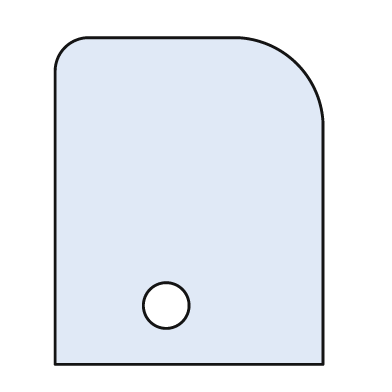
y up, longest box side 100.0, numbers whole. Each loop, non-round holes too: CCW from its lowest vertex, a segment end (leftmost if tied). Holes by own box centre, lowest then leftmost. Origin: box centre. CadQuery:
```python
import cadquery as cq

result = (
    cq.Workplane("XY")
    .moveTo(-41.0, -50.0)
    .lineTo(41.0, -50.0)
    .lineTo(41.0, 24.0)
    .threePointArc((33.0, 42.0), (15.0, 50.0))
    .lineTo(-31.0, 50.0)
    .threePointArc((-38.0, 47.0), (-41.0, 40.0))
    .close()
    .moveTo(-7.0, -32.0)
    .circle(7.0)
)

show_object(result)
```